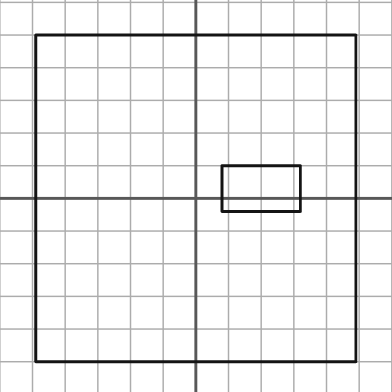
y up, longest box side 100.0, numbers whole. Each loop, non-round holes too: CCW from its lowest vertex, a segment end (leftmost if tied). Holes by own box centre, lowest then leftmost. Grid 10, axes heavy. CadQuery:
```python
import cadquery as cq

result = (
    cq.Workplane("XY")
    .moveTo(-49.0, -50.0)
    .lineTo(49.0, -50.0)
    .lineTo(49.0, 50.0)
    .lineTo(-49.0, 50.0)
    .close()
    .moveTo(8.0, -4.0)
    .lineTo(32.0, -4.0)
    .lineTo(32.0, 10.0)
    .lineTo(8.0, 10.0)
    .close()
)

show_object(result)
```